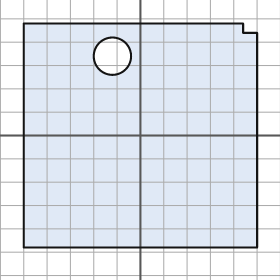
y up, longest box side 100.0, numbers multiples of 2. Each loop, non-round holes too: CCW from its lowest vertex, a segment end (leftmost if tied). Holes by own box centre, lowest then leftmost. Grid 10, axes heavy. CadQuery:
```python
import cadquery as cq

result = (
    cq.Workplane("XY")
    .moveTo(-50.0, -48.0)
    .lineTo(50.0, -48.0)
    .lineTo(50.0, 44.0)
    .lineTo(44.0, 44.0)
    .lineTo(44.0, 48.0)
    .lineTo(-50.0, 48.0)
    .close()
    .moveTo(-12.0, 34.0)
    .circle(8.0)
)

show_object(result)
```